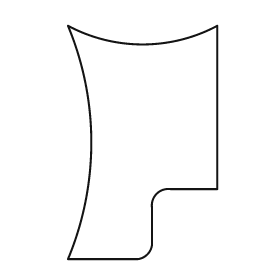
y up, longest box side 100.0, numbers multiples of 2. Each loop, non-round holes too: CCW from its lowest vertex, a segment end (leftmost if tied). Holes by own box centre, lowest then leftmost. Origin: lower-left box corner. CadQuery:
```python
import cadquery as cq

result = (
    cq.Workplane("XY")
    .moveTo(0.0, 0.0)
    .lineTo(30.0, 0.0)
    .threePointArc((34.0, 2.0), (36.0, 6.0))
    .lineTo(36.0, 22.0)
    .threePointArc((38.0, 28.0), (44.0, 30.0))
    .lineTo(64.0, 30.0)
    .lineTo(64.0, 100.0)
    .threePointArc((32.0, 92.0), (0.0, 100.0))
    .threePointArc((10.0, 50.0), (0.0, 0.0))
    .close()
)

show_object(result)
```